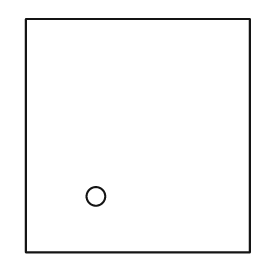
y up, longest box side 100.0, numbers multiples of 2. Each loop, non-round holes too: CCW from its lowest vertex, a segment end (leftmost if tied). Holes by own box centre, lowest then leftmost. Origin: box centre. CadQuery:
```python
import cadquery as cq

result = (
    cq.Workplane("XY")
    .moveTo(-48.0, -50.0)
    .lineTo(48.0, -50.0)
    .lineTo(48.0, 50.0)
    .lineTo(-48.0, 50.0)
    .close()
    .moveTo(-18.0, -26.0)
    .circle(4.0)
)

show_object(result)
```